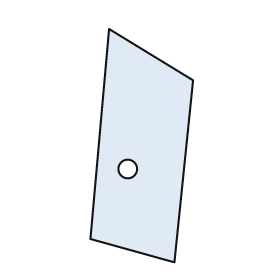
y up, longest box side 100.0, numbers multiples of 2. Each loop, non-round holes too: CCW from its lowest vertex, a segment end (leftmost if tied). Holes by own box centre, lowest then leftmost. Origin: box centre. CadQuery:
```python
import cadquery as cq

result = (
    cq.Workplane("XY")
    .moveTo(14.0, -50.0)
    .lineTo(22.0, 28.0)
    .lineTo(-14.0, 50.0)
    .lineTo(-22.0, -40.0)
    .close()
    .moveTo(-6.0, -10.0)
    .circle(4.0)
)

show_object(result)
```